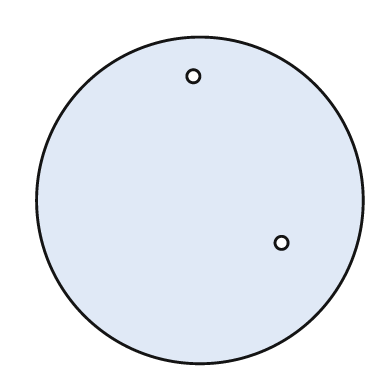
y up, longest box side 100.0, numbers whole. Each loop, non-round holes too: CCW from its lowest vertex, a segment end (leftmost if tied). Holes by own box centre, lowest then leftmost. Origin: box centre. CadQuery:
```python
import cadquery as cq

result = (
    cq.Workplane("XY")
    .moveTo(0.0, 0.0)
    .circle(50.0)
    .moveTo(25.0, -13.0)
    .circle(2.0)
    .moveTo(-2.0, 38.0)
    .circle(2.0)
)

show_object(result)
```